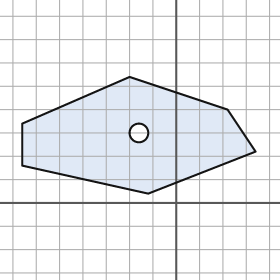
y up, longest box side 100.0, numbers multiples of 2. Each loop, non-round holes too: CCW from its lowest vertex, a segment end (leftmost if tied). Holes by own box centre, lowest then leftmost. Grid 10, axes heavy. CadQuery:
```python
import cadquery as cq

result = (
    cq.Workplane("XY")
    .moveTo(-12.0, 4.0)
    .lineTo(34.0, 22.0)
    .lineTo(22.0, 40.0)
    .lineTo(-20.0, 54.0)
    .lineTo(-66.0, 34.0)
    .lineTo(-66.0, 16.0)
    .close()
    .moveTo(-16.0, 30.0)
    .circle(4.0)
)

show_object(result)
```